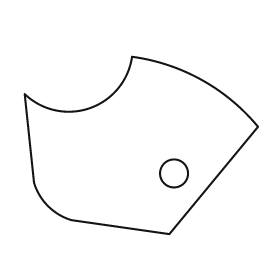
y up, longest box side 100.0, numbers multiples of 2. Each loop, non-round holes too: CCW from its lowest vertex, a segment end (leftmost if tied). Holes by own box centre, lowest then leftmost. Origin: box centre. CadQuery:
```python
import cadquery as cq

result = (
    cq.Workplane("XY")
    .moveTo(12.0, -38.0)
    .lineTo(50.0, 8.0)
    .threePointArc((26.0, 28.0), (-4.0, 38.0))
    .threePointArc((-22.0, 16.0), (-50.0, 22.0))
    .lineTo(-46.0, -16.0)
    .threePointArc((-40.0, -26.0), (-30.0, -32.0))
    .close()
    .moveTo(14.0, -12.0)
    .circle(6.0)
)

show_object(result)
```